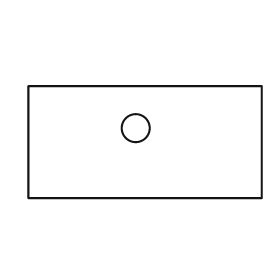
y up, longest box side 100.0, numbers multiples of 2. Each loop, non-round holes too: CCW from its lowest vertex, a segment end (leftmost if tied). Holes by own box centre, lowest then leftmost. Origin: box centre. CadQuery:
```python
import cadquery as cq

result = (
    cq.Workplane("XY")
    .moveTo(-50.0, -24.0)
    .lineTo(50.0, -24.0)
    .lineTo(50.0, 24.0)
    .lineTo(-50.0, 24.0)
    .close()
    .moveTo(-4.0, 6.0)
    .circle(6.0)
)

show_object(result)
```